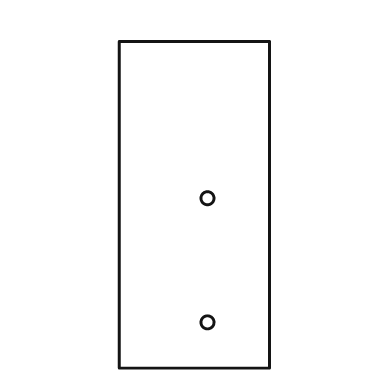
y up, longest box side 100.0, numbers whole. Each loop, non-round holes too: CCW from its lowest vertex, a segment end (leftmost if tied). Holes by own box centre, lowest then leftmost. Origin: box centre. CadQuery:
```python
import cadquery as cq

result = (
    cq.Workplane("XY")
    .moveTo(-23.0, -50.0)
    .lineTo(23.0, -50.0)
    .lineTo(23.0, 50.0)
    .lineTo(-23.0, 50.0)
    .close()
    .moveTo(4.0, -36.0)
    .circle(2.0)
    .moveTo(4.0, 2.0)
    .circle(2.0)
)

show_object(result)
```